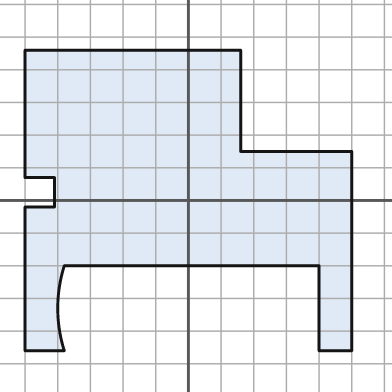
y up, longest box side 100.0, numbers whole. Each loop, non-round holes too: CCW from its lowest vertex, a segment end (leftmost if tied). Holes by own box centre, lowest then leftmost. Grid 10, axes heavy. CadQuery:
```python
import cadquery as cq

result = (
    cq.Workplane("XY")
    .moveTo(-50.0, -46.0)
    .lineTo(-38.0, -46.0)
    .threePointArc((-40.0, -33.0), (-38.0, -20.0))
    .lineTo(40.0, -20.0)
    .lineTo(40.0, -46.0)
    .lineTo(50.0, -46.0)
    .lineTo(50.0, 15.0)
    .lineTo(16.0, 15.0)
    .lineTo(16.0, 46.0)
    .lineTo(-50.0, 46.0)
    .lineTo(-50.0, 7.0)
    .lineTo(-41.0, 7.0)
    .lineTo(-41.0, -2.0)
    .lineTo(-50.0, -2.0)
    .close()
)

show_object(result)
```